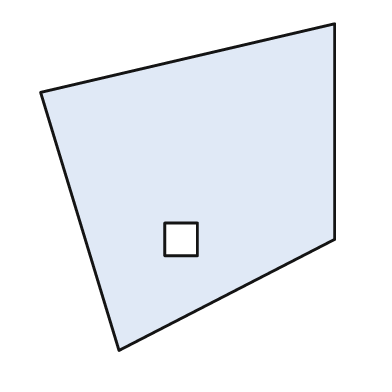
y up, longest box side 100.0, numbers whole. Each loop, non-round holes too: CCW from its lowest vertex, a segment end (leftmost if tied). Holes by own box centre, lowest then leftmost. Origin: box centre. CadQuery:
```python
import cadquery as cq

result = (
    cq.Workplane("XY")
    .moveTo(-21.0, -50.0)
    .lineTo(45.0, -16.0)
    .lineTo(45.0, 50.0)
    .lineTo(-45.0, 29.0)
    .close()
    .moveTo(-7.0, -21.0)
    .lineTo(3.0, -21.0)
    .lineTo(3.0, -11.0)
    .lineTo(-7.0, -11.0)
    .close()
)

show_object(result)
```